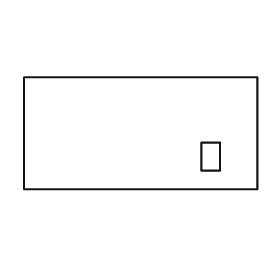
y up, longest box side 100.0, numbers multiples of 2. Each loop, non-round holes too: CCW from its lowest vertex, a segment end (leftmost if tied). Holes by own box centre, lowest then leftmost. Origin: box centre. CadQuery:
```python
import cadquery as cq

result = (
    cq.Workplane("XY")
    .moveTo(-50.0, -24.0)
    .lineTo(50.0, -24.0)
    .lineTo(50.0, 24.0)
    .lineTo(-50.0, 24.0)
    .close()
    .moveTo(26.0, -16.0)
    .lineTo(34.0, -16.0)
    .lineTo(34.0, -4.0)
    .lineTo(26.0, -4.0)
    .close()
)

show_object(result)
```